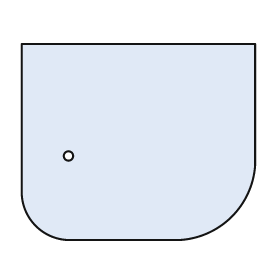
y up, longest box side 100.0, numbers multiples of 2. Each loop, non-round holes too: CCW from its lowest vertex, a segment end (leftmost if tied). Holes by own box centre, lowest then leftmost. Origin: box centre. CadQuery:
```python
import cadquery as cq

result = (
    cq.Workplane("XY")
    .moveTo(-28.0, -42.0)
    .lineTo(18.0, -42.0)
    .threePointArc((40.0, -32.0), (50.0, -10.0))
    .lineTo(50.0, 42.0)
    .lineTo(-50.0, 42.0)
    .lineTo(-50.0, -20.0)
    .threePointArc((-44.0, -36.0), (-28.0, -42.0))
    .close()
    .moveTo(-30.0, -6.0)
    .circle(2.0)
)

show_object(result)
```